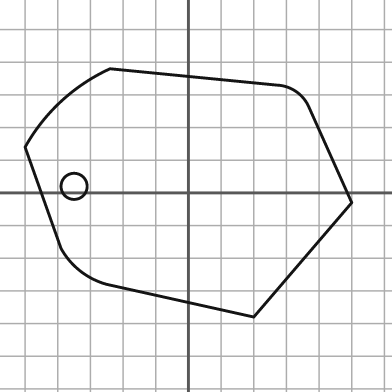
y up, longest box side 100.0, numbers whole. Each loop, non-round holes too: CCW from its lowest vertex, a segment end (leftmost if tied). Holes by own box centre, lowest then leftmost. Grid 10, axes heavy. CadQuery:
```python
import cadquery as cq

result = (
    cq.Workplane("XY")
    .moveTo(20.0, -38.0)
    .lineTo(50.0, -3.0)
    .lineTo(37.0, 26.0)
    .threePointArc((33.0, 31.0), (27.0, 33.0))
    .lineTo(-24.0, 38.0)
    .threePointArc((-39.0, 28.0), (-50.0, 14.0))
    .lineTo(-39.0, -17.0)
    .threePointArc((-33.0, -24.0), (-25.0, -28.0))
    .close()
    .moveTo(-35.0, 2.0)
    .circle(4.0)
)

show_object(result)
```